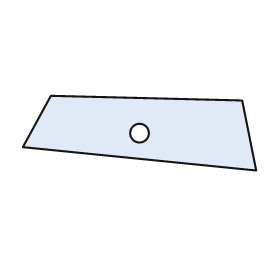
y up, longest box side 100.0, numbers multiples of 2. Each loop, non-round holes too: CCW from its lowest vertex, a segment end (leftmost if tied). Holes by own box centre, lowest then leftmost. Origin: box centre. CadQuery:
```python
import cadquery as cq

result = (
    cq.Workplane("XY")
    .moveTo(50.0, -16.0)
    .lineTo(44.0, 14.0)
    .lineTo(-38.0, 16.0)
    .lineTo(-50.0, -6.0)
    .close()
    .moveTo(0.0, 0.0)
    .circle(4.0)
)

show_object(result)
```